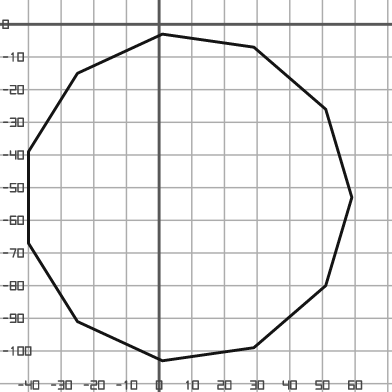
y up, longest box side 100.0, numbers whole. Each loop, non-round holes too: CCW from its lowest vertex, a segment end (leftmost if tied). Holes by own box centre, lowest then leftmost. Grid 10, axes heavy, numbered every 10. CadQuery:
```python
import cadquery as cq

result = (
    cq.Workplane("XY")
    .moveTo(1.0, -103.0)
    .lineTo(29.0, -99.0)
    .lineTo(51.0, -80.0)
    .lineTo(59.0, -53.0)
    .lineTo(51.0, -26.0)
    .lineTo(29.0, -7.0)
    .lineTo(1.0, -3.0)
    .lineTo(-25.0, -15.0)
    .lineTo(-40.0, -39.0)
    .lineTo(-40.0, -67.0)
    .lineTo(-25.0, -91.0)
    .close()
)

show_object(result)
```